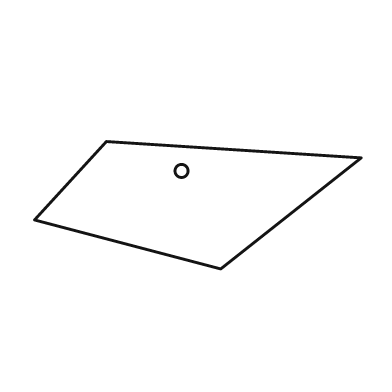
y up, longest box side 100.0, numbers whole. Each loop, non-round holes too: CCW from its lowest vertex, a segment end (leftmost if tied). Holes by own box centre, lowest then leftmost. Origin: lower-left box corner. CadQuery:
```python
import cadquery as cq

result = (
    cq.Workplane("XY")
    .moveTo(57.0, 0.0)
    .lineTo(100.0, 34.0)
    .lineTo(22.0, 39.0)
    .lineTo(0.0, 15.0)
    .close()
    .moveTo(45.0, 30.0)
    .circle(2.0)
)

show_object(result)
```